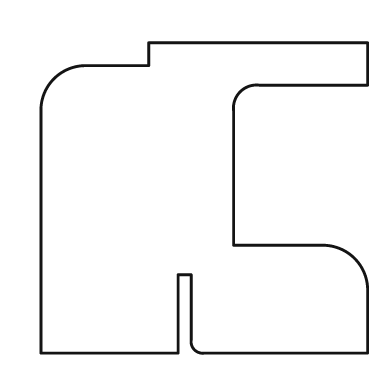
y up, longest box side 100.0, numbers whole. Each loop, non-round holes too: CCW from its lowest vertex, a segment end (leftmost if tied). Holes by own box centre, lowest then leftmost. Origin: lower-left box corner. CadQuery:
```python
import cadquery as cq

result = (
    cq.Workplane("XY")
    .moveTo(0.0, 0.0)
    .lineTo(42.0, 0.0)
    .lineTo(42.0, 24.0)
    .lineTo(46.0, 24.0)
    .lineTo(46.0, 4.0)
    .threePointArc((47.0, 1.0), (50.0, 0.0))
    .lineTo(100.0, 0.0)
    .lineTo(100.0, 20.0)
    .threePointArc((96.0, 29.0), (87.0, 33.0))
    .lineTo(59.0, 33.0)
    .lineTo(59.0, 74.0)
    .threePointArc((61.0, 80.0), (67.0, 82.0))
    .lineTo(100.0, 82.0)
    .lineTo(100.0, 95.0)
    .lineTo(33.0, 95.0)
    .lineTo(33.0, 88.0)
    .lineTo(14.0, 88.0)
    .threePointArc((4.0, 84.0), (0.0, 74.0))
    .close()
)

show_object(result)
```